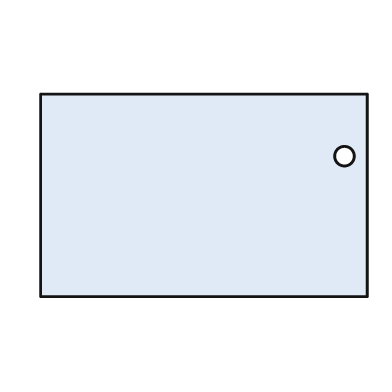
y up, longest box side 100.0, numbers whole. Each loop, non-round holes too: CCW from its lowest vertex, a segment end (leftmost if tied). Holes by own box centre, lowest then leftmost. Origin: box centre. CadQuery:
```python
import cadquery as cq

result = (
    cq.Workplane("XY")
    .moveTo(-50.0, -31.0)
    .lineTo(50.0, -31.0)
    .lineTo(50.0, 31.0)
    .lineTo(-50.0, 31.0)
    .close()
    .moveTo(43.0, 12.0)
    .circle(3.0)
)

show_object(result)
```